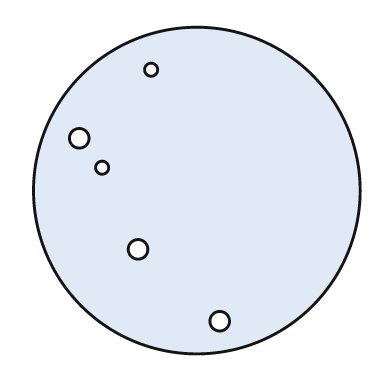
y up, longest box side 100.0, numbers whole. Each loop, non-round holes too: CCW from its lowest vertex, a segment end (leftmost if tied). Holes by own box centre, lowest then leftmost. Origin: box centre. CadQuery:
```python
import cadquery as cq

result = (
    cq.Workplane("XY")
    .moveTo(0.0, 0.0)
    .circle(50.0)
    .moveTo(7.0, -40.0)
    .circle(3.0)
    .moveTo(-18.0, -18.0)
    .circle(3.0)
    .moveTo(-29.0, 7.0)
    .circle(2.0)
    .moveTo(-36.0, 16.0)
    .circle(3.0)
    .moveTo(-14.0, 37.0)
    .circle(2.0)
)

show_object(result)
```